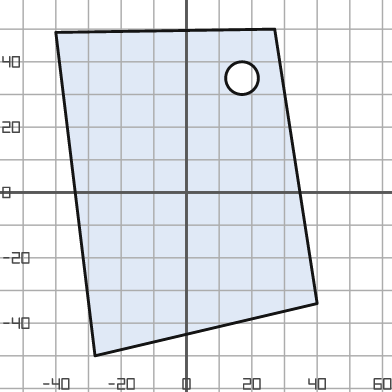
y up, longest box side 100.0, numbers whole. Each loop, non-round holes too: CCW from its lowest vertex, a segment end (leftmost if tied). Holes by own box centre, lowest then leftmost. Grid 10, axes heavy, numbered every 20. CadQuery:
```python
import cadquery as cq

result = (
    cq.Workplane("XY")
    .moveTo(-28.0, -50.0)
    .lineTo(40.0, -34.0)
    .lineTo(27.0, 50.0)
    .lineTo(-40.0, 49.0)
    .close()
    .moveTo(17.0, 35.0)
    .circle(5.0)
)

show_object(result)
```